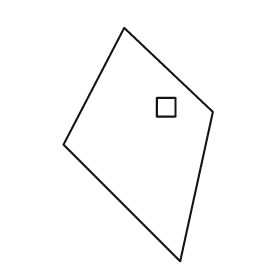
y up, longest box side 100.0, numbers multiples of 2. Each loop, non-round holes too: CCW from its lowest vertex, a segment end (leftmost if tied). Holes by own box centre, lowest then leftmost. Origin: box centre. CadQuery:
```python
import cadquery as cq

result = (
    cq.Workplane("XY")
    .moveTo(18.0, -50.0)
    .lineTo(32.0, 14.0)
    .lineTo(-6.0, 50.0)
    .lineTo(-32.0, 0.0)
    .close()
    .moveTo(8.0, 12.0)
    .lineTo(16.0, 12.0)
    .lineTo(16.0, 20.0)
    .lineTo(8.0, 20.0)
    .close()
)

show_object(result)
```